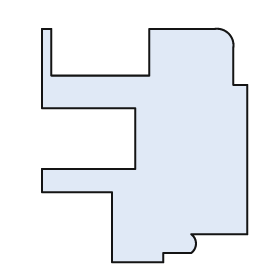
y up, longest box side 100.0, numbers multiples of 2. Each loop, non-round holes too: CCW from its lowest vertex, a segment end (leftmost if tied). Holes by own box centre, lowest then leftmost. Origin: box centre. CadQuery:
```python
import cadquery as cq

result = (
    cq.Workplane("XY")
    .moveTo(-14.0, -50.0)
    .lineTo(8.0, -50.0)
    .lineTo(8.0, -46.0)
    .lineTo(20.0, -46.0)
    .threePointArc((22.0, -42.0), (20.0, -38.0))
    .lineTo(44.0, -38.0)
    .lineTo(44.0, 26.0)
    .lineTo(38.0, 26.0)
    .lineTo(38.0, 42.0)
    .threePointArc((36.0, 48.0), (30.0, 50.0))
    .lineTo(2.0, 50.0)
    .lineTo(2.0, 30.0)
    .lineTo(-40.0, 30.0)
    .lineTo(-40.0, 50.0)
    .lineTo(-44.0, 50.0)
    .lineTo(-44.0, 16.0)
    .lineTo(-4.0, 16.0)
    .lineTo(-4.0, -10.0)
    .lineTo(-44.0, -10.0)
    .lineTo(-44.0, -20.0)
    .lineTo(-14.0, -20.0)
    .close()
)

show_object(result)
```